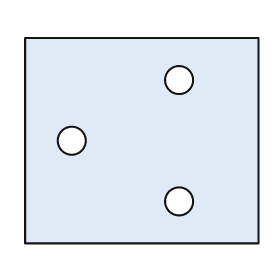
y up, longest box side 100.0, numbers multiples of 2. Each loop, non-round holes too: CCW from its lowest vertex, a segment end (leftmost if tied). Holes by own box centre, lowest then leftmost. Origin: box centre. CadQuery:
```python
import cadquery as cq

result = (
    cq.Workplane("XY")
    .moveTo(-50.0, -44.0)
    .lineTo(50.0, -44.0)
    .lineTo(50.0, 44.0)
    .lineTo(-50.0, 44.0)
    .close()
    .moveTo(16.0, -26.0)
    .circle(6.0)
    .moveTo(-30.0, 0.0)
    .circle(6.0)
    .moveTo(16.0, 26.0)
    .circle(6.0)
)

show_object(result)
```